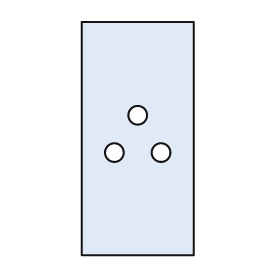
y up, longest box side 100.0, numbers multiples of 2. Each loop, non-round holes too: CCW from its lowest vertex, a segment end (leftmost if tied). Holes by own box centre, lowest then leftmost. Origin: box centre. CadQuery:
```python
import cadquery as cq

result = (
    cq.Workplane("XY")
    .moveTo(-24.0, -50.0)
    .lineTo(24.0, -50.0)
    .lineTo(24.0, 50.0)
    .lineTo(-24.0, 50.0)
    .close()
    .moveTo(-10.0, -6.0)
    .circle(4.0)
    .moveTo(10.0, -6.0)
    .circle(4.0)
    .moveTo(0.0, 10.0)
    .circle(4.0)
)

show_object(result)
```